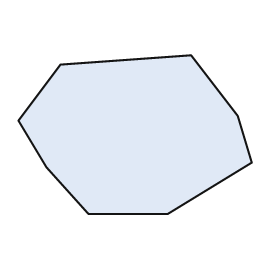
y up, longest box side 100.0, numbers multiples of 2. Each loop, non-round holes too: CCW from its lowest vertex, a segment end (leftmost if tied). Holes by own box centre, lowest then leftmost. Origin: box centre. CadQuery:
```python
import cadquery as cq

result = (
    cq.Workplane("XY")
    .moveTo(-20.0, -34.0)
    .lineTo(14.0, -34.0)
    .lineTo(50.0, -12.0)
    .lineTo(44.0, 8.0)
    .lineTo(24.0, 34.0)
    .lineTo(-32.0, 30.0)
    .lineTo(-50.0, 6.0)
    .lineTo(-38.0, -14.0)
    .close()
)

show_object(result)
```